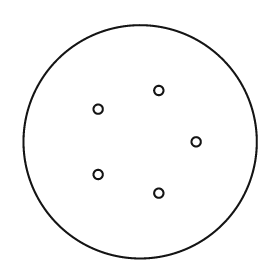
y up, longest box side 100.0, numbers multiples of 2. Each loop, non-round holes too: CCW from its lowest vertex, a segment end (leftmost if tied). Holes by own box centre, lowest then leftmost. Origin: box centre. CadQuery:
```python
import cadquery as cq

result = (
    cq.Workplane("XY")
    .moveTo(0.0, 0.0)
    .circle(50.0)
    .moveTo(8.0, -22.0)
    .circle(2.0)
    .moveTo(-18.0, -14.0)
    .circle(2.0)
    .moveTo(24.0, 0.0)
    .circle(2.0)
    .moveTo(-18.0, 14.0)
    .circle(2.0)
    .moveTo(8.0, 22.0)
    .circle(2.0)
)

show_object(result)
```